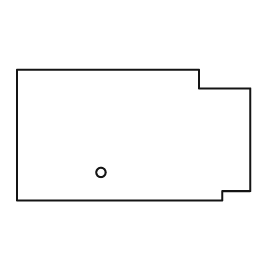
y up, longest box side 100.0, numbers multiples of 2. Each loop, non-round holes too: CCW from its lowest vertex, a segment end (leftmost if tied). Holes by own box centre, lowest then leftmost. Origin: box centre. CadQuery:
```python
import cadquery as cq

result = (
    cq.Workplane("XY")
    .moveTo(-50.0, -28.0)
    .lineTo(38.0, -28.0)
    .lineTo(38.0, -24.0)
    .lineTo(50.0, -24.0)
    .lineTo(50.0, 20.0)
    .lineTo(28.0, 20.0)
    .lineTo(28.0, 28.0)
    .lineTo(-50.0, 28.0)
    .close()
    .moveTo(-14.0, -16.0)
    .circle(2.0)
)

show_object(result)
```